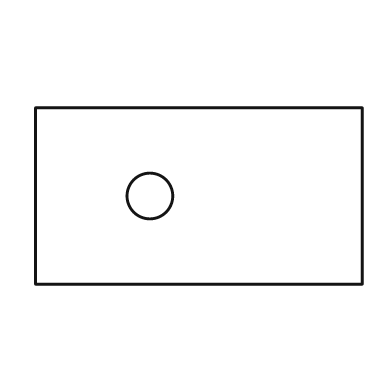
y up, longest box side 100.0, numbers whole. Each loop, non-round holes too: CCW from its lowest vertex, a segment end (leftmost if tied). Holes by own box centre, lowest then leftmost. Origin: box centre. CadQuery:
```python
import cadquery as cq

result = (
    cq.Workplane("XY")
    .moveTo(-50.0, -27.0)
    .lineTo(50.0, -27.0)
    .lineTo(50.0, 27.0)
    .lineTo(-50.0, 27.0)
    .close()
    .moveTo(-15.0, 0.0)
    .circle(7.0)
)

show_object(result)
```